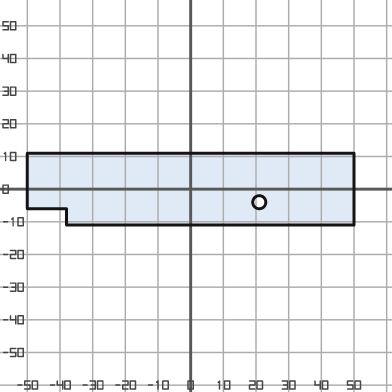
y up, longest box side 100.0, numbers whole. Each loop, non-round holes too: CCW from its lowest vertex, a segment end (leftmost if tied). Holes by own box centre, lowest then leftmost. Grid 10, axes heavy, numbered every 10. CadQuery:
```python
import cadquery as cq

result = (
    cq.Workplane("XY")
    .moveTo(-38.0, -11.0)
    .lineTo(50.0, -11.0)
    .lineTo(50.0, 11.0)
    .lineTo(-50.0, 11.0)
    .lineTo(-50.0, -6.0)
    .lineTo(-38.0, -6.0)
    .close()
    .moveTo(21.0, -4.0)
    .circle(2.0)
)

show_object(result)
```